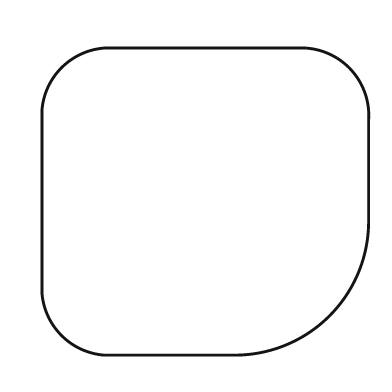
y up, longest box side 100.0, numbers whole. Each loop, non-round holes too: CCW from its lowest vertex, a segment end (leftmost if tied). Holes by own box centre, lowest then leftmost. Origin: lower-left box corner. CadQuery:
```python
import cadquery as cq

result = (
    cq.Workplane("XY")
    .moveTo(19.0, 0.0)
    .lineTo(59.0, 0.0)
    .threePointArc((88.0, 12.0), (100.0, 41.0))
    .lineTo(100.0, 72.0)
    .threePointArc((94.0, 88.0), (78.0, 94.0))
    .lineTo(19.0, 94.0)
    .threePointArc((6.0, 88.0), (0.0, 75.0))
    .lineTo(0.0, 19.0)
    .threePointArc((6.0, 6.0), (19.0, 0.0))
    .close()
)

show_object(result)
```